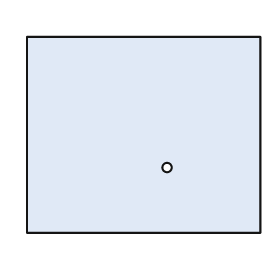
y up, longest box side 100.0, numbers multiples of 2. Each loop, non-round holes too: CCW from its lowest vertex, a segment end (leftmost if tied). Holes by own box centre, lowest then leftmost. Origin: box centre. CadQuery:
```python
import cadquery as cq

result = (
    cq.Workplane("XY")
    .moveTo(-50.0, -42.0)
    .lineTo(50.0, -42.0)
    .lineTo(50.0, 42.0)
    .lineTo(-50.0, 42.0)
    .close()
    .moveTo(10.0, -14.0)
    .circle(2.0)
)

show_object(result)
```